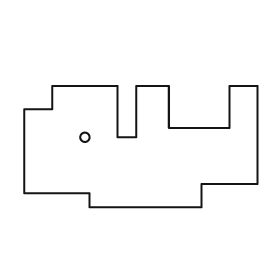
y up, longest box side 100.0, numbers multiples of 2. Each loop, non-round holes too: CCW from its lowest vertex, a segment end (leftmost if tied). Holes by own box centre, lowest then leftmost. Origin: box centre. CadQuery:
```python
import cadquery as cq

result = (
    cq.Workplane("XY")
    .moveTo(-22.0, -26.0)
    .lineTo(26.0, -26.0)
    .lineTo(26.0, -16.0)
    .lineTo(50.0, -16.0)
    .lineTo(50.0, 26.0)
    .lineTo(38.0, 26.0)
    .lineTo(38.0, 8.0)
    .lineTo(12.0, 8.0)
    .lineTo(12.0, 26.0)
    .lineTo(-2.0, 26.0)
    .lineTo(-2.0, 4.0)
    .lineTo(-10.0, 4.0)
    .lineTo(-10.0, 26.0)
    .lineTo(-38.0, 26.0)
    .lineTo(-38.0, 16.0)
    .lineTo(-50.0, 16.0)
    .lineTo(-50.0, -20.0)
    .lineTo(-22.0, -20.0)
    .close()
    .moveTo(-24.0, 4.0)
    .circle(2.0)
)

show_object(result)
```